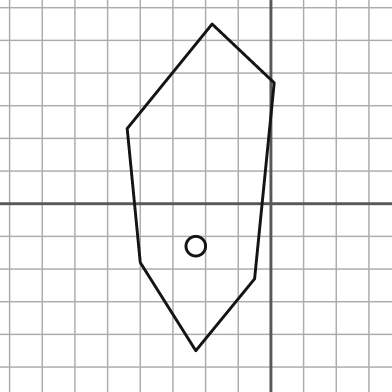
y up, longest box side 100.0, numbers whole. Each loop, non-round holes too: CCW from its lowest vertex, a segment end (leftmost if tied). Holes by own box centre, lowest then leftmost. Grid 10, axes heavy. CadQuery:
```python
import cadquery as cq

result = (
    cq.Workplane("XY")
    .moveTo(-23.0, -45.0)
    .lineTo(-5.0, -23.0)
    .lineTo(1.0, 37.0)
    .lineTo(-18.0, 55.0)
    .lineTo(-44.0, 23.0)
    .lineTo(-40.0, -18.0)
    .close()
    .moveTo(-23.0, -13.0)
    .circle(3.0)
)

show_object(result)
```